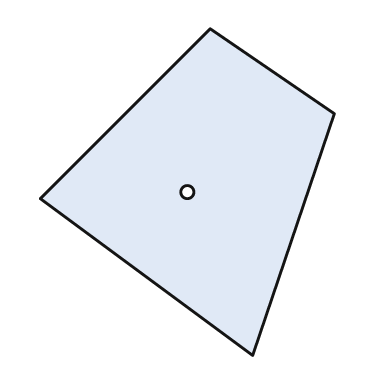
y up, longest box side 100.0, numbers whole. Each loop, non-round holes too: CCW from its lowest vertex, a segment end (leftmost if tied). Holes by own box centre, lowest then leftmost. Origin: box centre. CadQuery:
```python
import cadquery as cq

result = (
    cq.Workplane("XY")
    .moveTo(20.0, -50.0)
    .lineTo(45.0, 24.0)
    .lineTo(7.0, 50.0)
    .lineTo(-45.0, -2.0)
    .close()
    .moveTo(0.0, 0.0)
    .circle(2.0)
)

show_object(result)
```